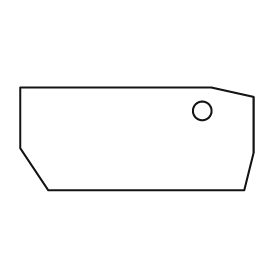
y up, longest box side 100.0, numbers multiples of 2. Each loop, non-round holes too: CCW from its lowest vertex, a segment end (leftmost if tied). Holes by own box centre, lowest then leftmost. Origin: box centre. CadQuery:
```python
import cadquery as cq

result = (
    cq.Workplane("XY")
    .moveTo(-38.0, -22.0)
    .lineTo(46.0, -22.0)
    .lineTo(50.0, -6.0)
    .lineTo(50.0, 18.0)
    .lineTo(32.0, 22.0)
    .lineTo(-50.0, 22.0)
    .lineTo(-50.0, -4.0)
    .close()
    .moveTo(28.0, 12.0)
    .circle(4.0)
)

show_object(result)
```